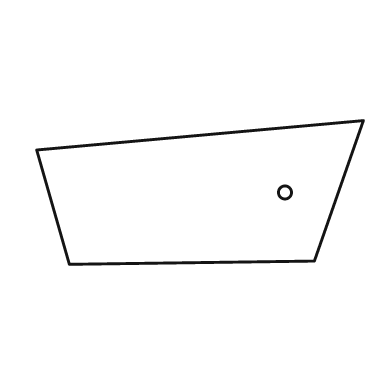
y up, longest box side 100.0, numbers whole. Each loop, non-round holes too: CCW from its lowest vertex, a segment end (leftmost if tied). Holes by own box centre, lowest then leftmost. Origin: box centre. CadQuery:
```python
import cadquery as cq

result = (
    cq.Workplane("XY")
    .moveTo(-40.0, -22.0)
    .lineTo(35.0, -21.0)
    .lineTo(50.0, 22.0)
    .lineTo(-50.0, 13.0)
    .close()
    .moveTo(26.0, 0.0)
    .circle(2.0)
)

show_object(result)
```